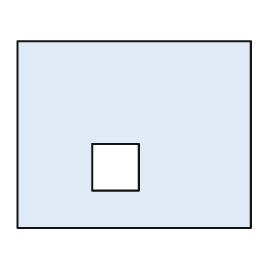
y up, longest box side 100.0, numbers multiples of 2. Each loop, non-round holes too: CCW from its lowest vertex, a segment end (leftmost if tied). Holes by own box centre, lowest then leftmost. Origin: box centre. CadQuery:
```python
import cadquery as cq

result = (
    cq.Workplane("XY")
    .moveTo(-50.0, -40.0)
    .lineTo(50.0, -40.0)
    .lineTo(50.0, 40.0)
    .lineTo(-50.0, 40.0)
    .close()
    .moveTo(-18.0, -24.0)
    .lineTo(2.0, -24.0)
    .lineTo(2.0, -4.0)
    .lineTo(-18.0, -4.0)
    .close()
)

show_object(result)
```